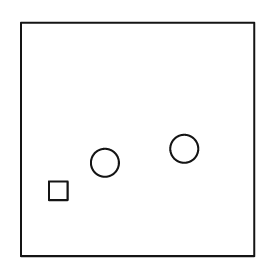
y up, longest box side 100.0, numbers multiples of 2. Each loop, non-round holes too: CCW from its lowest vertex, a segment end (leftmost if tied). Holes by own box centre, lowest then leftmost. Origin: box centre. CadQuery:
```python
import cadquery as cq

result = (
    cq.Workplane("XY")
    .moveTo(-50.0, -50.0)
    .lineTo(50.0, -50.0)
    .lineTo(50.0, 50.0)
    .lineTo(-50.0, 50.0)
    .close()
    .moveTo(-38.0, -26.0)
    .lineTo(-30.0, -26.0)
    .lineTo(-30.0, -18.0)
    .lineTo(-38.0, -18.0)
    .close()
    .moveTo(-14.0, -10.0)
    .circle(6.0)
    .moveTo(20.0, -4.0)
    .circle(6.0)
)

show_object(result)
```